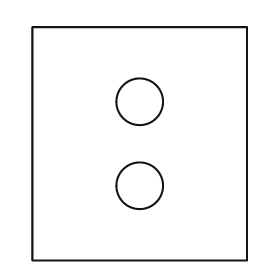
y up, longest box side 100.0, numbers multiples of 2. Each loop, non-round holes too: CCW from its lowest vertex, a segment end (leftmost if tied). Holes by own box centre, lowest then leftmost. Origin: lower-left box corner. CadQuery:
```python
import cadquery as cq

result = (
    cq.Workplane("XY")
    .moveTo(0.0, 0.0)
    .lineTo(92.0, 0.0)
    .lineTo(92.0, 100.0)
    .lineTo(0.0, 100.0)
    .close()
    .moveTo(46.0, 32.0)
    .circle(10.0)
    .moveTo(46.0, 68.0)
    .circle(10.0)
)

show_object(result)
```